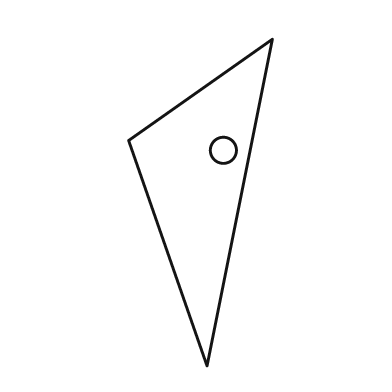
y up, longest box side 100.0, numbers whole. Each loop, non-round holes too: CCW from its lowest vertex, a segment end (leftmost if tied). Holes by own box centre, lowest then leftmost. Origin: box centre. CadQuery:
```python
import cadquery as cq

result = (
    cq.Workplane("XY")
    .moveTo(2.0, -50.0)
    .lineTo(22.0, 50.0)
    .lineTo(-22.0, 19.0)
    .close()
    .moveTo(7.0, 16.0)
    .circle(4.0)
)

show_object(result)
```